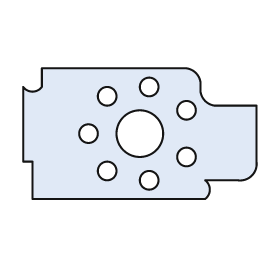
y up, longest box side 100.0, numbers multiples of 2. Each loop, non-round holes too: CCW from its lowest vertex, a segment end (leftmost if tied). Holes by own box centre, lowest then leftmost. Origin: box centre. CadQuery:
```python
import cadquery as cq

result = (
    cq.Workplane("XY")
    .moveTo(-46.0, -28.0)
    .lineTo(28.0, -28.0)
    .threePointArc((30.0, -24.0), (28.0, -20.0))
    .lineTo(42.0, -20.0)
    .threePointArc((48.0, -18.0), (50.0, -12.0))
    .lineTo(50.0, 12.0)
    .lineTo(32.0, 12.0)
    .threePointArc((28.0, 14.0), (26.0, 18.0))
    .lineTo(26.0, 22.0)
    .threePointArc((24.0, 26.0), (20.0, 28.0))
    .lineTo(-42.0, 28.0)
    .lineTo(-42.0, 20.0)
    .threePointArc((-46.0, 18.0), (-50.0, 20.0))
    .lineTo(-50.0, -12.0)
    .lineTo(-46.0, -12.0)
    .close()
    .moveTo(4.0, -20.0)
    .circle(4.0)
    .moveTo(-14.0, -16.0)
    .circle(4.0)
    .moveTo(20.0, -10.0)
    .circle(4.0)
    .moveTo(-22.0, 0.0)
    .circle(4.0)
    .moveTo(0.0, 0.0)
    .circle(10.0)
    .moveTo(20.0, 10.0)
    .circle(4.0)
    .moveTo(-14.0, 16.0)
    .circle(4.0)
    .moveTo(4.0, 20.0)
    .circle(4.0)
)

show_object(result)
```